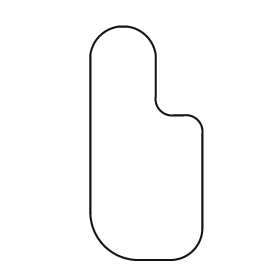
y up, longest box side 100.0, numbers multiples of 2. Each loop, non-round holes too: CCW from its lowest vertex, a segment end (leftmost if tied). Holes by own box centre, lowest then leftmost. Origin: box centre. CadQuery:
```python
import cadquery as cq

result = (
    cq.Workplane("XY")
    .moveTo(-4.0, -50.0)
    .lineTo(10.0, -50.0)
    .threePointArc((20.0, -46.0), (24.0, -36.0))
    .lineTo(24.0, 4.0)
    .threePointArc((22.0, 10.0), (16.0, 12.0))
    .lineTo(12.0, 12.0)
    .threePointArc((6.0, 14.0), (4.0, 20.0))
    .lineTo(4.0, 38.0)
    .threePointArc((0.0, 46.0), (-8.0, 50.0))
    .lineTo(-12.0, 50.0)
    .threePointArc((-20.0, 46.0), (-24.0, 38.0))
    .lineTo(-24.0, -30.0)
    .threePointArc((-18.0, -44.0), (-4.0, -50.0))
    .close()
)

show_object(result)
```